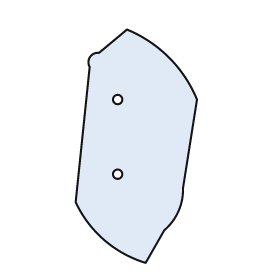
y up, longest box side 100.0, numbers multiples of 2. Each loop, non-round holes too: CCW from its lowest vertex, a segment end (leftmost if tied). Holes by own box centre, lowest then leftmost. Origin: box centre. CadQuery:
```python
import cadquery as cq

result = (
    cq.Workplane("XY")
    .moveTo(4.0, -50.0)
    .lineTo(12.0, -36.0)
    .threePointArc((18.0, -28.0), (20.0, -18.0))
    .lineTo(26.0, 20.0)
    .threePointArc((14.0, 38.0), (-4.0, 50.0))
    .lineTo(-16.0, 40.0)
    .threePointArc((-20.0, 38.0), (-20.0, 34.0))
    .lineTo(-26.0, -24.0)
    .threePointArc((-14.0, -40.0), (4.0, -50.0))
    .close()
    .moveTo(-8.0, -12.0)
    .circle(2.0)
    .moveTo(-8.0, 20.0)
    .circle(2.0)
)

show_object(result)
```